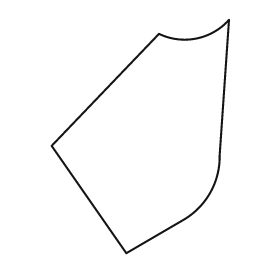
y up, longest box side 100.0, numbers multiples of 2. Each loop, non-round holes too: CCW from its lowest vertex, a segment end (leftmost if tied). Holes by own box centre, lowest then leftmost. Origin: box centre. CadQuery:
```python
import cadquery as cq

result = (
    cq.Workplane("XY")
    .moveTo(-6.0, -50.0)
    .lineTo(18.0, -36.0)
    .threePointArc((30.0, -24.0), (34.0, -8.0))
    .lineTo(38.0, 50.0)
    .threePointArc((24.0, 42.0), (8.0, 44.0))
    .lineTo(-38.0, -4.0)
    .close()
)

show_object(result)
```